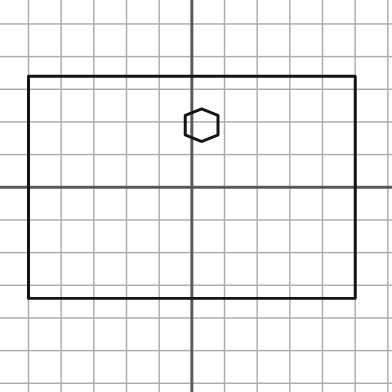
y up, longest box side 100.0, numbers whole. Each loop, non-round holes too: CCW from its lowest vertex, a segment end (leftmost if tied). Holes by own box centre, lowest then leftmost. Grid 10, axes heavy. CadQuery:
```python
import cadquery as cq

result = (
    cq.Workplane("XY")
    .moveTo(-50.0, -34.0)
    .lineTo(50.0, -34.0)
    .lineTo(50.0, 34.0)
    .lineTo(-50.0, 34.0)
    .close()
    .moveTo(3.0, 14.0)
    .lineTo(8.0, 16.0)
    .lineTo(8.0, 22.0)
    .lineTo(3.0, 24.0)
    .lineTo(-2.0, 22.0)
    .lineTo(-2.0, 16.0)
    .close()
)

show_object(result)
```